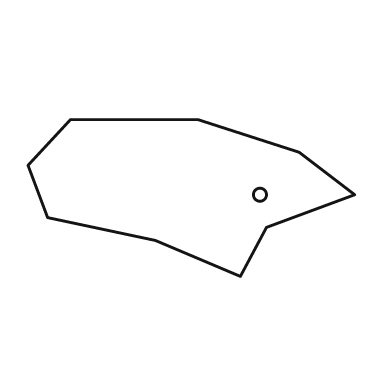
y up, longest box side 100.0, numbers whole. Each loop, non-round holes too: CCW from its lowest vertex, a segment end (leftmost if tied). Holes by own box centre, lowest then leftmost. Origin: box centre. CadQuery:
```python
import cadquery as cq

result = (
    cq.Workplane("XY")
    .moveTo(15.0, -24.0)
    .lineTo(23.0, -9.0)
    .lineTo(50.0, 1.0)
    .lineTo(33.0, 14.0)
    .lineTo(2.0, 24.0)
    .lineTo(-37.0, 24.0)
    .lineTo(-50.0, 10.0)
    .lineTo(-44.0, -6.0)
    .lineTo(-11.0, -13.0)
    .close()
    .moveTo(21.0, 1.0)
    .circle(2.0)
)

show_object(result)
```